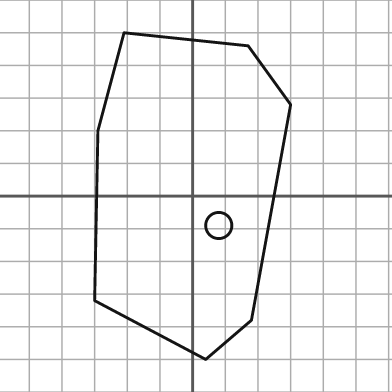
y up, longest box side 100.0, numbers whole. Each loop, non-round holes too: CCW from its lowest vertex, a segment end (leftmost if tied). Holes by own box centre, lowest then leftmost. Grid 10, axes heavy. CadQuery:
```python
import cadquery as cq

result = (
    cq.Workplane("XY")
    .moveTo(4.0, -50.0)
    .lineTo(18.0, -38.0)
    .lineTo(30.0, 28.0)
    .lineTo(17.0, 46.0)
    .lineTo(-21.0, 50.0)
    .lineTo(-29.0, 20.0)
    .lineTo(-30.0, -32.0)
    .close()
    .moveTo(8.0, -9.0)
    .circle(4.0)
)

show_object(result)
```